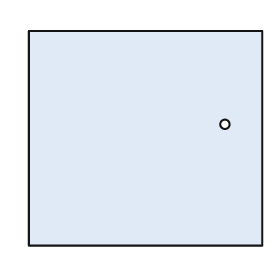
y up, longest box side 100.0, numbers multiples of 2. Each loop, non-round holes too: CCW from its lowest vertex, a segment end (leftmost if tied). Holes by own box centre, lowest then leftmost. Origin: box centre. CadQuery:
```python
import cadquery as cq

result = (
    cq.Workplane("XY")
    .moveTo(-50.0, -46.0)
    .lineTo(50.0, -46.0)
    .lineTo(50.0, 46.0)
    .lineTo(-50.0, 46.0)
    .close()
    .moveTo(34.0, 6.0)
    .circle(2.0)
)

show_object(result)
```